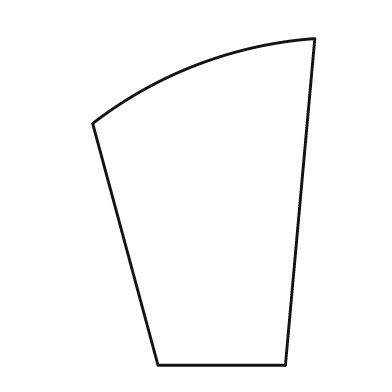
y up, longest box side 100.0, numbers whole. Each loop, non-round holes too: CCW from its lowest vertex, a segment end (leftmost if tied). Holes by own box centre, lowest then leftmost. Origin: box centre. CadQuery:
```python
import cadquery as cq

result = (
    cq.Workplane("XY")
    .moveTo(-14.0, -50.0)
    .lineTo(25.0, -50.0)
    .lineTo(34.0, 50.0)
    .threePointArc((-2.0, 42.0), (-34.0, 24.0))
    .close()
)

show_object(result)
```